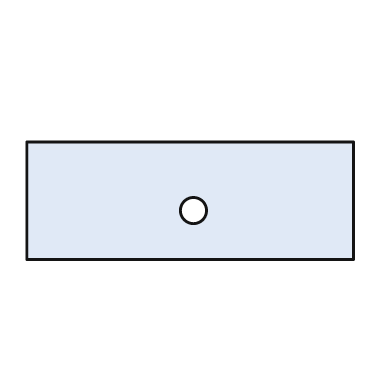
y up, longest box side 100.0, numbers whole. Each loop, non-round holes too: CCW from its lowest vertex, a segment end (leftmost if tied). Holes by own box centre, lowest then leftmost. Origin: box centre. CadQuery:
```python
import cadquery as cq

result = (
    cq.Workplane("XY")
    .moveTo(-50.0, -18.0)
    .lineTo(50.0, -18.0)
    .lineTo(50.0, 18.0)
    .lineTo(-50.0, 18.0)
    .close()
    .moveTo(1.0, -3.0)
    .circle(4.0)
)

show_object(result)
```